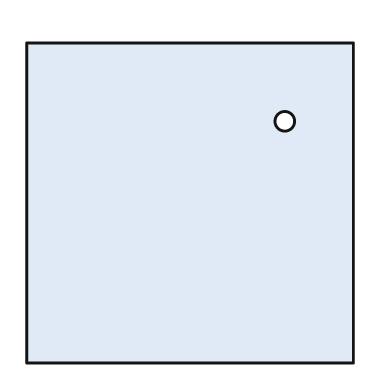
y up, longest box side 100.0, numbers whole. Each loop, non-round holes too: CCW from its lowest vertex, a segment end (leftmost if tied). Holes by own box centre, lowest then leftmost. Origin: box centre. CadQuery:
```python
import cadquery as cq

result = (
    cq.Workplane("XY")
    .moveTo(-50.0, -49.0)
    .lineTo(50.0, -49.0)
    .lineTo(50.0, 49.0)
    .lineTo(-50.0, 49.0)
    .close()
    .moveTo(29.0, 25.0)
    .circle(3.0)
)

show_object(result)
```